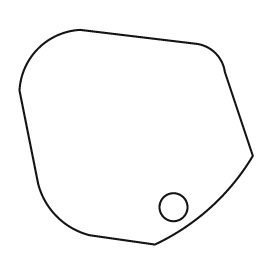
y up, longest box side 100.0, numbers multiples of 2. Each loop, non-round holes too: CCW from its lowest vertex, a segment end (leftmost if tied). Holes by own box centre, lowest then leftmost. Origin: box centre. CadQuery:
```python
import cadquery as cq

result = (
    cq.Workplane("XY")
    .moveTo(8.0, -46.0)
    .threePointArc((32.0, -30.0), (50.0, -8.0))
    .lineTo(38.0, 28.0)
    .threePointArc((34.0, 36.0), (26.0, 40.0))
    .lineTo(-24.0, 46.0)
    .threePointArc((-42.0, 38.0), (-50.0, 20.0))
    .lineTo(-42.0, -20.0)
    .threePointArc((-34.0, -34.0), (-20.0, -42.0))
    .close()
    .moveTo(16.0, -30.0)
    .circle(6.0)
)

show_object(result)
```